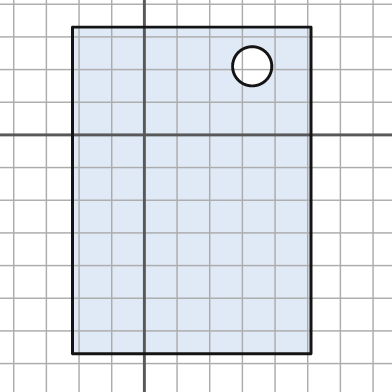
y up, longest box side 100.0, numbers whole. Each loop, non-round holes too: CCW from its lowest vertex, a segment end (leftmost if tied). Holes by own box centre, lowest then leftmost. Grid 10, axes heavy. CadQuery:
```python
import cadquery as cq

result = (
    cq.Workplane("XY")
    .moveTo(-22.0, -67.0)
    .lineTo(51.0, -67.0)
    .lineTo(51.0, 33.0)
    .lineTo(-22.0, 33.0)
    .close()
    .moveTo(33.0, 21.0)
    .circle(6.0)
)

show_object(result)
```